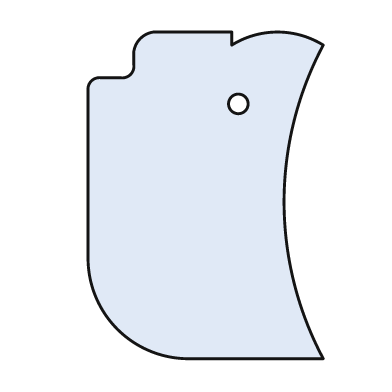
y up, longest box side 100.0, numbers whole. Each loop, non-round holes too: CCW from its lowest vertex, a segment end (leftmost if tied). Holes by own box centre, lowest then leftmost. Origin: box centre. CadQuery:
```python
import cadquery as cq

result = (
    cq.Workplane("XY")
    .moveTo(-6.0, -50.0)
    .lineTo(36.0, -50.0)
    .threePointArc((24.0, -2.0), (36.0, 46.0))
    .threePointArc((22.0, 50.0), (8.0, 46.0))
    .lineTo(8.0, 50.0)
    .lineTo(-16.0, 50.0)
    .threePointArc((-20.0, 48.0), (-22.0, 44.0))
    .lineTo(-22.0, 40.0)
    .threePointArc((-23.0, 37.0), (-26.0, 36.0))
    .lineTo(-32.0, 36.0)
    .threePointArc((-35.0, 35.0), (-36.0, 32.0))
    .lineTo(-36.0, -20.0)
    .threePointArc((-27.0, -41.0), (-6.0, -50.0))
    .close()
    .moveTo(10.0, 28.0)
    .circle(3.0)
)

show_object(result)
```